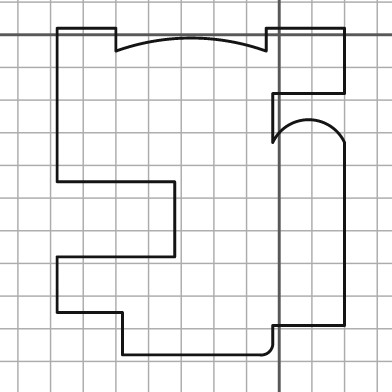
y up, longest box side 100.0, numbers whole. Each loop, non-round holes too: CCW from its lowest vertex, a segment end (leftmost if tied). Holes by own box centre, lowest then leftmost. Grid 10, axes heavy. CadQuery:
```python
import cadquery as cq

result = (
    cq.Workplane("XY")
    .moveTo(-48.0, -98.0)
    .lineTo(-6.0, -98.0)
    .threePointArc((-3.0, -97.0), (-2.0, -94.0))
    .lineTo(-2.0, -89.0)
    .lineTo(20.0, -89.0)
    .lineTo(20.0, -33.0)
    .threePointArc((9.0, -26.0), (-2.0, -33.0))
    .lineTo(-2.0, -18.0)
    .lineTo(20.0, -18.0)
    .lineTo(20.0, 2.0)
    .lineTo(-4.0, 2.0)
    .lineTo(-4.0, -5.0)
    .threePointArc((-27.0, -1.0), (-50.0, -5.0))
    .lineTo(-50.0, 2.0)
    .lineTo(-68.0, 2.0)
    .lineTo(-68.0, -45.0)
    .lineTo(-32.0, -45.0)
    .lineTo(-32.0, -68.0)
    .lineTo(-68.0, -68.0)
    .lineTo(-68.0, -85.0)
    .lineTo(-48.0, -85.0)
    .close()
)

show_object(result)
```